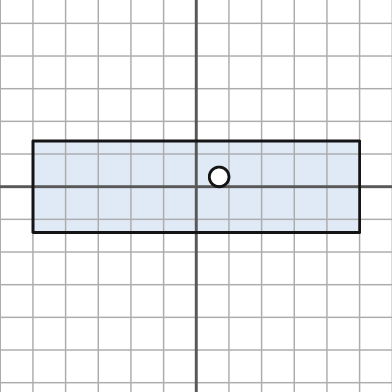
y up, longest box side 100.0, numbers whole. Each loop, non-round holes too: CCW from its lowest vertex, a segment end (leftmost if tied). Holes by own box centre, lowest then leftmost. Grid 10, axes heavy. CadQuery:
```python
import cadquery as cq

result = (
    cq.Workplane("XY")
    .moveTo(-50.0, -14.0)
    .lineTo(50.0, -14.0)
    .lineTo(50.0, 14.0)
    .lineTo(-50.0, 14.0)
    .close()
    .moveTo(7.0, 3.0)
    .circle(3.0)
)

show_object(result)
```